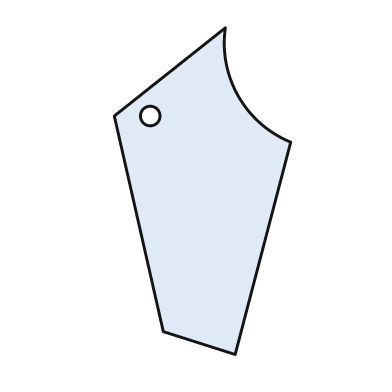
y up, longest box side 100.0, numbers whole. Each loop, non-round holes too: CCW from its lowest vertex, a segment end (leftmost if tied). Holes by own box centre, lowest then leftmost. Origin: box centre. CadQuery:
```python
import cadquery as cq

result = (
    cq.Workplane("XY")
    .moveTo(10.0, -50.0)
    .lineTo(27.0, 15.0)
    .threePointArc((11.0, 29.0), (7.0, 50.0))
    .lineTo(-27.0, 23.0)
    .lineTo(-12.0, -43.0)
    .close()
    .moveTo(-16.0, 23.0)
    .circle(3.0)
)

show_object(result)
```